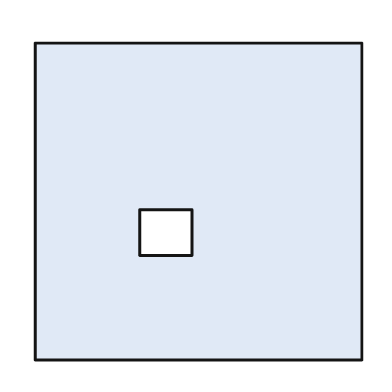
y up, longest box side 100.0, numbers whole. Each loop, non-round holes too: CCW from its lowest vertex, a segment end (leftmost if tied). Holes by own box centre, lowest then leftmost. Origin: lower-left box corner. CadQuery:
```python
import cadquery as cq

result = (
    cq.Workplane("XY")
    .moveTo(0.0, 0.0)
    .lineTo(100.0, 0.0)
    .lineTo(100.0, 97.0)
    .lineTo(0.0, 97.0)
    .close()
    .moveTo(32.0, 32.0)
    .lineTo(48.0, 32.0)
    .lineTo(48.0, 46.0)
    .lineTo(32.0, 46.0)
    .close()
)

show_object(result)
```